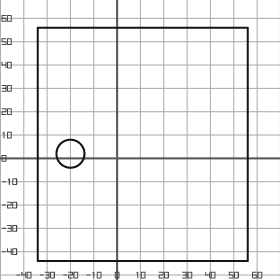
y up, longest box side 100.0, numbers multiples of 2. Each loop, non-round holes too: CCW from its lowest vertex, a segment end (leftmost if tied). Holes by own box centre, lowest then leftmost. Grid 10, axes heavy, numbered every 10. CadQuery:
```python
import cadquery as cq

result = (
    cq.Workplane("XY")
    .moveTo(-34.0, -44.0)
    .lineTo(56.0, -44.0)
    .lineTo(56.0, 56.0)
    .lineTo(-34.0, 56.0)
    .close()
    .moveTo(-20.0, 2.0)
    .circle(6.0)
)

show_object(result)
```